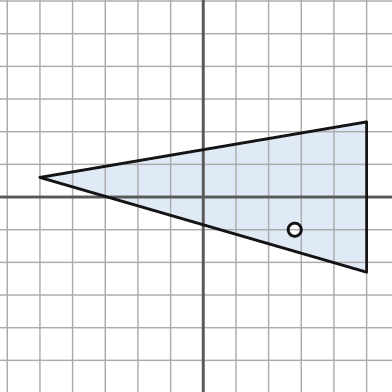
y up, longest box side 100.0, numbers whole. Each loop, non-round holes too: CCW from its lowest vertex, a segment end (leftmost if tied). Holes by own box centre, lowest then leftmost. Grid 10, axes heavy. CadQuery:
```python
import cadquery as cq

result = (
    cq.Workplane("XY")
    .moveTo(50.0, -23.0)
    .lineTo(50.0, 23.0)
    .lineTo(-50.0, 6.0)
    .close()
    .moveTo(28.0, -10.0)
    .circle(2.0)
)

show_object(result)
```